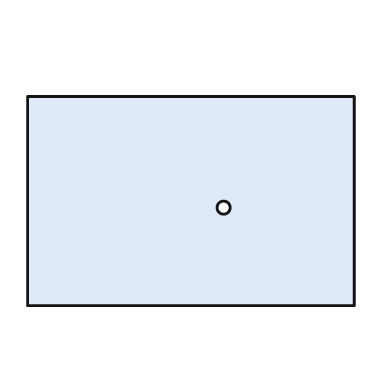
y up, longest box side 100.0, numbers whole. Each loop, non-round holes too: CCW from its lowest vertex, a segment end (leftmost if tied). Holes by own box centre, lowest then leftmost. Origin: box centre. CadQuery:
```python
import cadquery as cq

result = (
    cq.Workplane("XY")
    .moveTo(-50.0, -32.0)
    .lineTo(50.0, -32.0)
    .lineTo(50.0, 32.0)
    .lineTo(-50.0, 32.0)
    .close()
    .moveTo(10.0, -2.0)
    .circle(2.0)
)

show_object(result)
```